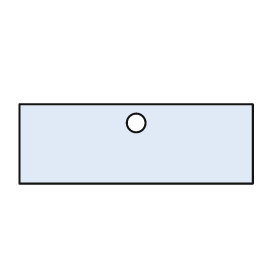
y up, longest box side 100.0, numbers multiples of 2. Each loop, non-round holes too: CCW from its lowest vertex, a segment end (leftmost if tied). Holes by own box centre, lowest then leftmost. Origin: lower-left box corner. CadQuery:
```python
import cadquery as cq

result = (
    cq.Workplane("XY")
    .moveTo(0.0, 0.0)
    .lineTo(100.0, 0.0)
    .lineTo(100.0, 34.0)
    .lineTo(0.0, 34.0)
    .close()
    .moveTo(50.0, 26.0)
    .circle(4.0)
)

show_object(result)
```